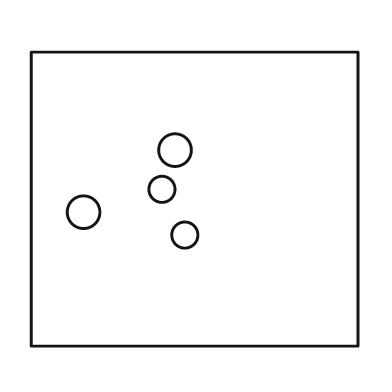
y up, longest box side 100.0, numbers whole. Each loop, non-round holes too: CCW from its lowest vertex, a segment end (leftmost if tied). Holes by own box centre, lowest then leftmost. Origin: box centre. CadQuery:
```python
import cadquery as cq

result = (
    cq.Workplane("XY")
    .moveTo(-50.0, -45.0)
    .lineTo(50.0, -45.0)
    .lineTo(50.0, 45.0)
    .lineTo(-50.0, 45.0)
    .close()
    .moveTo(-3.0, -11.0)
    .circle(4.0)
    .moveTo(-34.0, -4.0)
    .circle(5.0)
    .moveTo(-10.0, 3.0)
    .circle(4.0)
    .moveTo(-6.0, 15.0)
    .circle(5.0)
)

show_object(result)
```